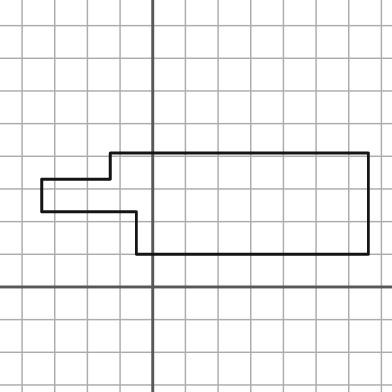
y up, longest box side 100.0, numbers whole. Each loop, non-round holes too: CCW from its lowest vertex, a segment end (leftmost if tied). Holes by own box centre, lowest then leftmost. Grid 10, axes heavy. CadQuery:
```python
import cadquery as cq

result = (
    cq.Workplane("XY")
    .moveTo(-5.0, 10.0)
    .lineTo(66.0, 10.0)
    .lineTo(66.0, 41.0)
    .lineTo(-13.0, 41.0)
    .lineTo(-13.0, 33.0)
    .lineTo(-34.0, 33.0)
    .lineTo(-34.0, 23.0)
    .lineTo(-5.0, 23.0)
    .close()
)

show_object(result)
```